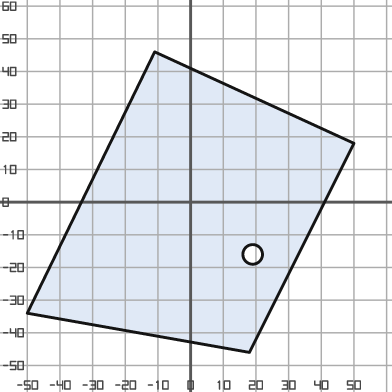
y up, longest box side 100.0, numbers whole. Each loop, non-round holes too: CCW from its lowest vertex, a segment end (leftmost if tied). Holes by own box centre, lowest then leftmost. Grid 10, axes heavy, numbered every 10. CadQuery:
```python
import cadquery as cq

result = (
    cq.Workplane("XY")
    .moveTo(18.0, -46.0)
    .lineTo(50.0, 18.0)
    .lineTo(-11.0, 46.0)
    .lineTo(-50.0, -34.0)
    .close()
    .moveTo(19.0, -16.0)
    .circle(3.0)
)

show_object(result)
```